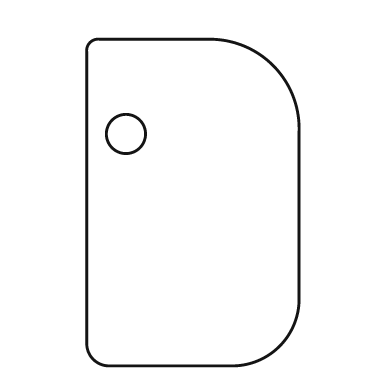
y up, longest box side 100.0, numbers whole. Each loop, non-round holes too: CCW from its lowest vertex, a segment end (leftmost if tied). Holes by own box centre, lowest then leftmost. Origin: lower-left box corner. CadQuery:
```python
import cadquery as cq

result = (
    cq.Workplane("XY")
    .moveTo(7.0, 0.0)
    .lineTo(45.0, 0.0)
    .threePointArc((59.0, 6.0), (65.0, 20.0))
    .lineTo(65.0, 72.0)
    .threePointArc((57.0, 92.0), (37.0, 100.0))
    .lineTo(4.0, 100.0)
    .threePointArc((1.0, 99.0), (0.0, 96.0))
    .lineTo(0.0, 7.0)
    .threePointArc((2.0, 2.0), (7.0, 0.0))
    .close()
    .moveTo(12.0, 71.0)
    .circle(6.0)
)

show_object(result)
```